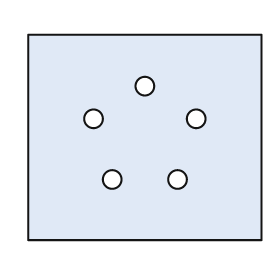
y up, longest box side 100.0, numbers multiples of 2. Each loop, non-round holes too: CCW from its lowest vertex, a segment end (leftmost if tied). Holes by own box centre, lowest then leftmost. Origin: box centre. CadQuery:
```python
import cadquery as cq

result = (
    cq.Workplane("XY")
    .moveTo(-50.0, -44.0)
    .lineTo(50.0, -44.0)
    .lineTo(50.0, 44.0)
    .lineTo(-50.0, 44.0)
    .close()
    .moveTo(-14.0, -18.0)
    .circle(4.0)
    .moveTo(14.0, -18.0)
    .circle(4.0)
    .moveTo(-22.0, 8.0)
    .circle(4.0)
    .moveTo(22.0, 8.0)
    .circle(4.0)
    .moveTo(0.0, 22.0)
    .circle(4.0)
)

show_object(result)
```